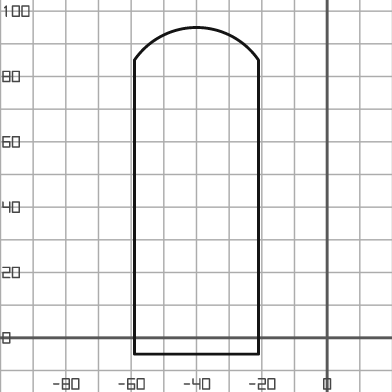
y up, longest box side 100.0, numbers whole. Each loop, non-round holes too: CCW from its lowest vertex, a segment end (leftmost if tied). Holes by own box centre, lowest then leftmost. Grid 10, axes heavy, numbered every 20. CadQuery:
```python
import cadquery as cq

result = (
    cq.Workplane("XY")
    .moveTo(-59.0, -5.0)
    .lineTo(-21.0, -5.0)
    .lineTo(-21.0, 85.0)
    .threePointArc((-40.0, 95.0), (-59.0, 85.0))
    .close()
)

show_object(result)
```